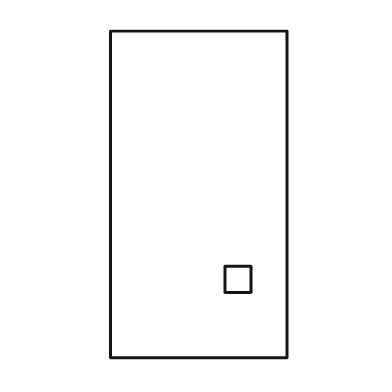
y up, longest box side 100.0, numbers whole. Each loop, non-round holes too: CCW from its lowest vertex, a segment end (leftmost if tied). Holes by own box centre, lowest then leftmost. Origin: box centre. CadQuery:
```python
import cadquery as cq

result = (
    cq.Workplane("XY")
    .moveTo(-27.0, -50.0)
    .lineTo(27.0, -50.0)
    .lineTo(27.0, 50.0)
    .lineTo(-27.0, 50.0)
    .close()
    .moveTo(8.0, -30.0)
    .lineTo(16.0, -30.0)
    .lineTo(16.0, -22.0)
    .lineTo(8.0, -22.0)
    .close()
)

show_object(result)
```